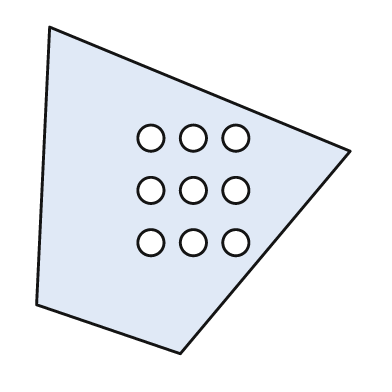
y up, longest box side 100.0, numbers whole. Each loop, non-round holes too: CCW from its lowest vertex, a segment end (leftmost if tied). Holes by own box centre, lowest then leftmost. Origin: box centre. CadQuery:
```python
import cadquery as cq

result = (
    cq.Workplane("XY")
    .moveTo(-4.0, -50.0)
    .lineTo(48.0, 12.0)
    .lineTo(-44.0, 50.0)
    .lineTo(-48.0, -35.0)
    .close()
    .moveTo(-13.0, -16.0)
    .circle(4.0)
    .moveTo(0.0, -16.0)
    .circle(4.0)
    .moveTo(13.0, -16.0)
    .circle(4.0)
    .moveTo(-13.0, 0.0)
    .circle(4.0)
    .moveTo(0.0, 0.0)
    .circle(4.0)
    .moveTo(13.0, 0.0)
    .circle(4.0)
    .moveTo(-13.0, 16.0)
    .circle(4.0)
    .moveTo(0.0, 16.0)
    .circle(4.0)
    .moveTo(13.0, 16.0)
    .circle(4.0)
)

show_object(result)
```